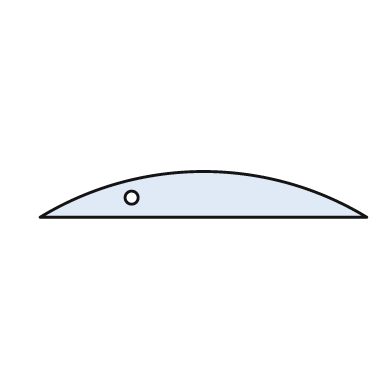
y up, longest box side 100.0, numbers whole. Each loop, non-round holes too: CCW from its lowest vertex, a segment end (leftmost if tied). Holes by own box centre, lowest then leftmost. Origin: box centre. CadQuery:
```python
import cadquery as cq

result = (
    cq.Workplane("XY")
    .moveTo(-50.0, -7.0)
    .lineTo(50.0, -7.0)
    .threePointArc((0.0, 7.0), (-50.0, -7.0))
    .close()
    .moveTo(-22.0, -1.0)
    .circle(2.0)
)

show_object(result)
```